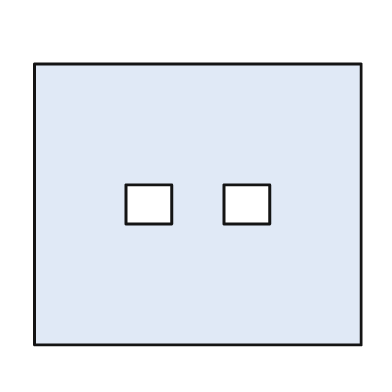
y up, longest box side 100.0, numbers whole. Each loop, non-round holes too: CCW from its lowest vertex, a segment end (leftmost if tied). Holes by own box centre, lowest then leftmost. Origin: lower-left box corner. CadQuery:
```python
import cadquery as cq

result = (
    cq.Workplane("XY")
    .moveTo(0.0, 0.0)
    .lineTo(100.0, 0.0)
    .lineTo(100.0, 86.0)
    .lineTo(0.0, 86.0)
    .close()
    .moveTo(28.0, 37.0)
    .lineTo(42.0, 37.0)
    .lineTo(42.0, 49.0)
    .lineTo(28.0, 49.0)
    .close()
    .moveTo(58.0, 37.0)
    .lineTo(72.0, 37.0)
    .lineTo(72.0, 49.0)
    .lineTo(58.0, 49.0)
    .close()
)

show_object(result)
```